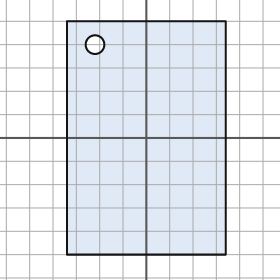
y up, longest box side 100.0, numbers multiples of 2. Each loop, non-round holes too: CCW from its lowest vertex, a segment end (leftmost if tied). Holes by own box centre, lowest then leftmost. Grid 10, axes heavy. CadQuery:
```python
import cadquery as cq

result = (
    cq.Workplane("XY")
    .moveTo(-34.0, -50.0)
    .lineTo(34.0, -50.0)
    .lineTo(34.0, 50.0)
    .lineTo(-34.0, 50.0)
    .close()
    .moveTo(-22.0, 40.0)
    .circle(4.0)
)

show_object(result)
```